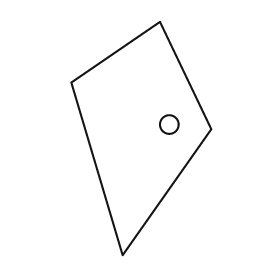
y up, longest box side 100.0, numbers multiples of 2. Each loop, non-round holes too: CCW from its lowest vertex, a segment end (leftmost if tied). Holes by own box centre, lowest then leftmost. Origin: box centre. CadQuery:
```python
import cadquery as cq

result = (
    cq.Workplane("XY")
    .moveTo(-8.0, -50.0)
    .lineTo(30.0, 4.0)
    .lineTo(8.0, 50.0)
    .lineTo(-30.0, 24.0)
    .close()
    .moveTo(12.0, 6.0)
    .circle(4.0)
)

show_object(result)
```